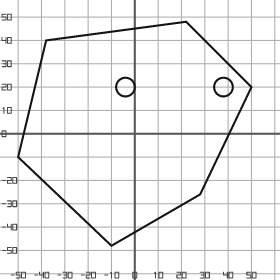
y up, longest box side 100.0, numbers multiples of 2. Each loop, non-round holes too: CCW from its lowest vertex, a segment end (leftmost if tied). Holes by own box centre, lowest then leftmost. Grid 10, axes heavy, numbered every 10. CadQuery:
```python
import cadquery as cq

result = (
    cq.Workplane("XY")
    .moveTo(-10.0, -48.0)
    .lineTo(28.0, -26.0)
    .lineTo(50.0, 20.0)
    .lineTo(22.0, 48.0)
    .lineTo(-38.0, 40.0)
    .lineTo(-50.0, -10.0)
    .close()
    .moveTo(-4.0, 20.0)
    .circle(4.0)
    .moveTo(38.0, 20.0)
    .circle(4.0)
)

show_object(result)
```